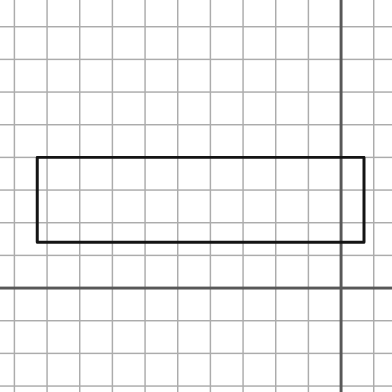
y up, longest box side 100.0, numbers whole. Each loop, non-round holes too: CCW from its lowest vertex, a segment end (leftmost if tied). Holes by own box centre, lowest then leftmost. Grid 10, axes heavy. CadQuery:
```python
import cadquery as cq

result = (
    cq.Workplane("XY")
    .moveTo(-93.0, 14.0)
    .lineTo(7.0, 14.0)
    .lineTo(7.0, 40.0)
    .lineTo(-93.0, 40.0)
    .close()
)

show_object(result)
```